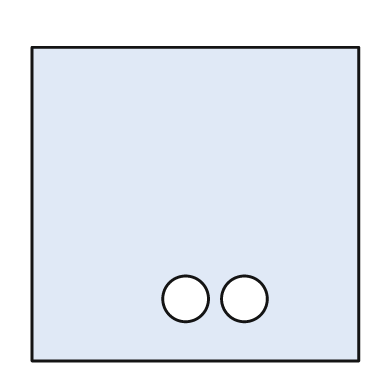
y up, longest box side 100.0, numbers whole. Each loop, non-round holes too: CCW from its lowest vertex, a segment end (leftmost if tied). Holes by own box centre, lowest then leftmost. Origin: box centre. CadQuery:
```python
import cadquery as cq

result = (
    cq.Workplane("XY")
    .moveTo(-50.0, -48.0)
    .lineTo(50.0, -48.0)
    .lineTo(50.0, 48.0)
    .lineTo(-50.0, 48.0)
    .close()
    .moveTo(-3.0, -29.0)
    .circle(7.0)
    .moveTo(15.0, -29.0)
    .circle(7.0)
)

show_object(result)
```